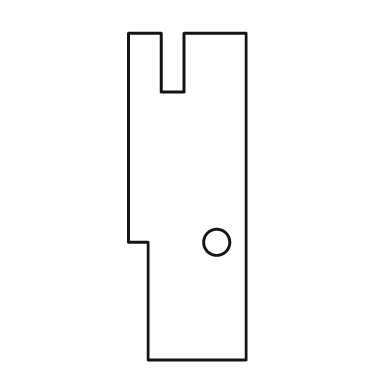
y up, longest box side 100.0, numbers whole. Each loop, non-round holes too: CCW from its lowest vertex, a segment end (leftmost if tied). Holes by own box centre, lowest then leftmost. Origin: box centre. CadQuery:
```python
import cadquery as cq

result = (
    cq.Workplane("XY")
    .moveTo(-12.0, -50.0)
    .lineTo(18.0, -50.0)
    .lineTo(18.0, 50.0)
    .lineTo(-1.0, 50.0)
    .lineTo(-1.0, 32.0)
    .lineTo(-8.0, 32.0)
    .lineTo(-8.0, 50.0)
    .lineTo(-18.0, 50.0)
    .lineTo(-18.0, -14.0)
    .lineTo(-12.0, -14.0)
    .close()
    .moveTo(9.0, -14.0)
    .circle(4.0)
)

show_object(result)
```